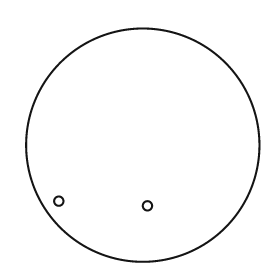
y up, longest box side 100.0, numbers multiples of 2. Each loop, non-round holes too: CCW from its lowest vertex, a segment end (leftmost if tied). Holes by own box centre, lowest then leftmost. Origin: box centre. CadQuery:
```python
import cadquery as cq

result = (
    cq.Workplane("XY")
    .moveTo(0.0, 0.0)
    .circle(50.0)
    .moveTo(2.0, -26.0)
    .circle(2.0)
    .moveTo(-36.0, -24.0)
    .circle(2.0)
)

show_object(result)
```